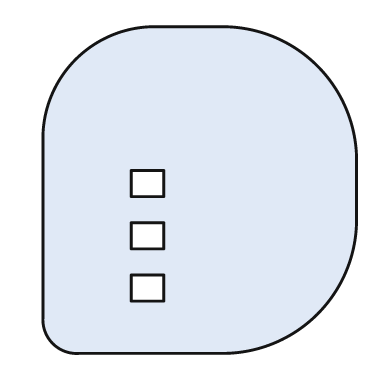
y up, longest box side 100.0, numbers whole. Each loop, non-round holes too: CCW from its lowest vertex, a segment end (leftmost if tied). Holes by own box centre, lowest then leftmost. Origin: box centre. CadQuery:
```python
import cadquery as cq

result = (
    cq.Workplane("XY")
    .moveTo(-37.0, -50.0)
    .lineTo(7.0, -50.0)
    .threePointArc((36.0, -38.0), (48.0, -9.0))
    .lineTo(48.0, 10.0)
    .threePointArc((36.0, 38.0), (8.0, 50.0))
    .lineTo(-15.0, 50.0)
    .threePointArc((-38.0, 40.0), (-48.0, 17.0))
    .lineTo(-48.0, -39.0)
    .threePointArc((-45.0, -47.0), (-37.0, -50.0))
    .close()
    .moveTo(-21.0, -34.0)
    .lineTo(-11.0, -34.0)
    .lineTo(-11.0, -26.0)
    .lineTo(-21.0, -26.0)
    .close()
    .moveTo(-21.0, -18.0)
    .lineTo(-11.0, -18.0)
    .lineTo(-11.0, -10.0)
    .lineTo(-21.0, -10.0)
    .close()
    .moveTo(-21.0, -2.0)
    .lineTo(-11.0, -2.0)
    .lineTo(-11.0, 6.0)
    .lineTo(-21.0, 6.0)
    .close()
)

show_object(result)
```